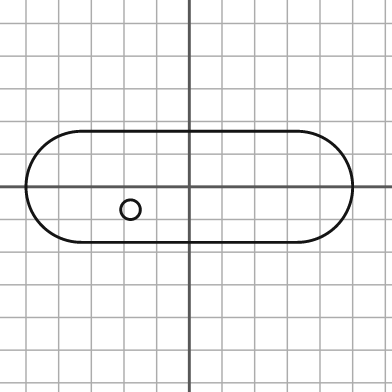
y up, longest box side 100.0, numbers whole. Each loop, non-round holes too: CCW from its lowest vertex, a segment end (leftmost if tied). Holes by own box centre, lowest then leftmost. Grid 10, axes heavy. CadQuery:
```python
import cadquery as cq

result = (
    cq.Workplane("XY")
    .moveTo(-33.0, -17.0)
    .lineTo(33.0, -17.0)
    .threePointArc((50.0, 0.0), (33.0, 17.0))
    .lineTo(-33.0, 17.0)
    .threePointArc((-50.0, 0.0), (-33.0, -17.0))
    .close()
    .moveTo(-18.0, -7.0)
    .circle(3.0)
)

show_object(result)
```